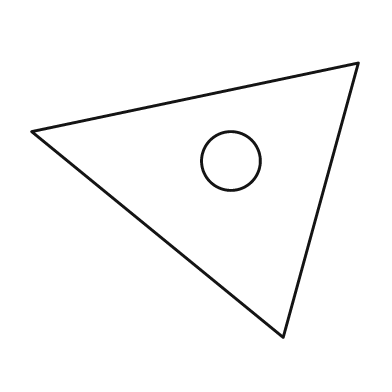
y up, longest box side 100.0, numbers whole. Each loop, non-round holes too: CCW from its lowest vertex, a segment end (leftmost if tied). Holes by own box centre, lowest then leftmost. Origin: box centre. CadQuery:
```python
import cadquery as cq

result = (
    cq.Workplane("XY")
    .moveTo(27.0, -42.0)
    .lineTo(50.0, 42.0)
    .lineTo(-50.0, 21.0)
    .close()
    .moveTo(11.0, 12.0)
    .circle(9.0)
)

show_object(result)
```